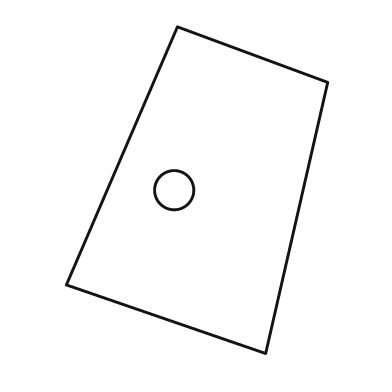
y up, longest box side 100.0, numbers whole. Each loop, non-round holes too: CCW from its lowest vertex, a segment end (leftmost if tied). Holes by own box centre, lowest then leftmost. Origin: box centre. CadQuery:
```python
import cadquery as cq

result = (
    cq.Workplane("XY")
    .moveTo(21.0, -50.0)
    .lineTo(40.0, 33.0)
    .lineTo(-6.0, 50.0)
    .lineTo(-40.0, -29.0)
    .close()
    .moveTo(-7.0, 0.0)
    .circle(6.0)
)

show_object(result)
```